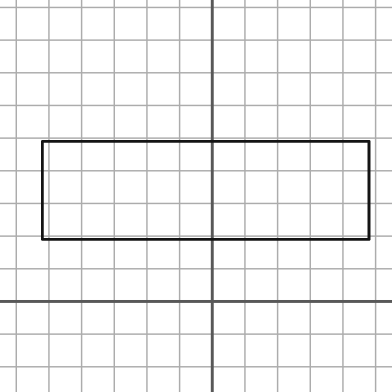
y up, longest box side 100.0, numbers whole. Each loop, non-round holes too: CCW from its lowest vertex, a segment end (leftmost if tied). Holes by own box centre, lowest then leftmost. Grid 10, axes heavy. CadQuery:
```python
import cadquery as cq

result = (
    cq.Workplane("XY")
    .moveTo(-52.0, 19.0)
    .lineTo(48.0, 19.0)
    .lineTo(48.0, 49.0)
    .lineTo(-52.0, 49.0)
    .close()
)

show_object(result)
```